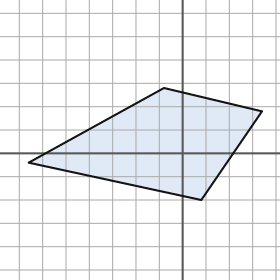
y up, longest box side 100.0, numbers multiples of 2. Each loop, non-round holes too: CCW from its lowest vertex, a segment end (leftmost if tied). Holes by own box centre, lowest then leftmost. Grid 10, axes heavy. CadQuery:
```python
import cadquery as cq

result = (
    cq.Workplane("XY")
    .moveTo(8.0, -20.0)
    .lineTo(34.0, 18.0)
    .lineTo(-8.0, 28.0)
    .lineTo(-66.0, -4.0)
    .close()
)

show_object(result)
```